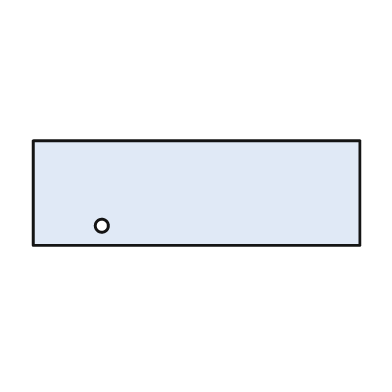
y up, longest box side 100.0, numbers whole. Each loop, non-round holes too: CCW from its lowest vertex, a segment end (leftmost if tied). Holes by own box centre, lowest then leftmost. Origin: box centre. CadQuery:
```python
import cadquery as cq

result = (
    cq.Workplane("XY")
    .moveTo(-50.0, -16.0)
    .lineTo(50.0, -16.0)
    .lineTo(50.0, 16.0)
    .lineTo(-50.0, 16.0)
    .close()
    .moveTo(-29.0, -10.0)
    .circle(2.0)
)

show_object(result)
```